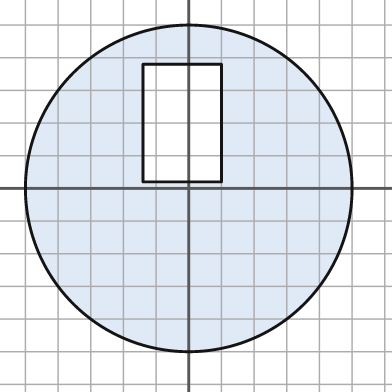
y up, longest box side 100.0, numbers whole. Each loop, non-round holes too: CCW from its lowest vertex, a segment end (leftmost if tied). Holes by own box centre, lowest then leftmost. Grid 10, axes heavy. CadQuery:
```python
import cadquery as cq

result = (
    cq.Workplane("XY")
    .moveTo(0.0, 0.0)
    .circle(50.0)
    .moveTo(-14.0, 2.0)
    .lineTo(10.0, 2.0)
    .lineTo(10.0, 38.0)
    .lineTo(-14.0, 38.0)
    .close()
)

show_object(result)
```